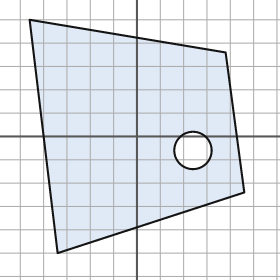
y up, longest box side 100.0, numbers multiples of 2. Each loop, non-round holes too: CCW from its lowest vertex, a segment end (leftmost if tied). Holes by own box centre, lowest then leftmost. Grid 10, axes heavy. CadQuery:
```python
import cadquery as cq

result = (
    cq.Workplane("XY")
    .moveTo(-34.0, -50.0)
    .lineTo(46.0, -24.0)
    .lineTo(38.0, 36.0)
    .lineTo(-46.0, 50.0)
    .close()
    .moveTo(24.0, -6.0)
    .circle(8.0)
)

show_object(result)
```